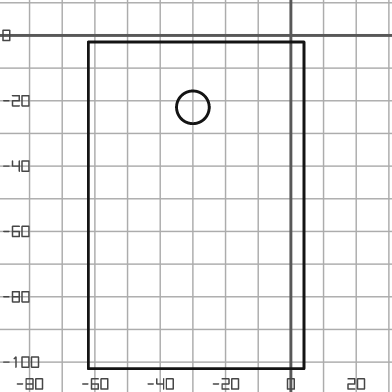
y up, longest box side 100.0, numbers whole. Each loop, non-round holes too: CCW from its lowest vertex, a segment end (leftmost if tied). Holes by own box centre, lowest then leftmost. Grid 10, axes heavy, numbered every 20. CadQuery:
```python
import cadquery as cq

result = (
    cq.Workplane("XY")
    .moveTo(-62.0, -102.0)
    .lineTo(4.0, -102.0)
    .lineTo(4.0, -2.0)
    .lineTo(-62.0, -2.0)
    .close()
    .moveTo(-30.0, -22.0)
    .circle(5.0)
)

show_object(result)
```